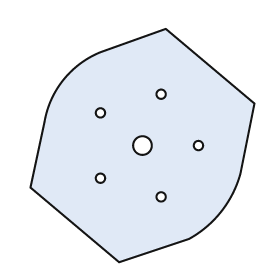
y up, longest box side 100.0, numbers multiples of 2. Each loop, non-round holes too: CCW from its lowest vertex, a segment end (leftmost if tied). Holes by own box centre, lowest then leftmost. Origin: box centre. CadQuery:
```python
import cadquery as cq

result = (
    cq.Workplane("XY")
    .moveTo(-10.0, -50.0)
    .lineTo(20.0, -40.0)
    .threePointArc((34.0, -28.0), (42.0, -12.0))
    .lineTo(48.0, 18.0)
    .lineTo(10.0, 50.0)
    .lineTo(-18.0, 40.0)
    .threePointArc((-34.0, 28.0), (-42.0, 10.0))
    .lineTo(-48.0, -18.0)
    .close()
    .moveTo(8.0, -22.0)
    .circle(2.0)
    .moveTo(-18.0, -14.0)
    .circle(2.0)
    .moveTo(0.0, 0.0)
    .circle(4.0)
    .moveTo(24.0, 0.0)
    .circle(2.0)
    .moveTo(-18.0, 14.0)
    .circle(2.0)
    .moveTo(8.0, 22.0)
    .circle(2.0)
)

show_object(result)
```